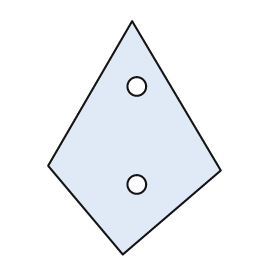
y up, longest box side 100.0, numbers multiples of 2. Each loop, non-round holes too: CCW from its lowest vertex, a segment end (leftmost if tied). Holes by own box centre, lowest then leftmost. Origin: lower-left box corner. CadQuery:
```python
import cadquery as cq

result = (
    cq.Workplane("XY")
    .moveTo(32.0, 0.0)
    .lineTo(74.0, 36.0)
    .lineTo(36.0, 100.0)
    .lineTo(0.0, 38.0)
    .close()
    .moveTo(38.0, 30.0)
    .circle(4.0)
    .moveTo(38.0, 72.0)
    .circle(4.0)
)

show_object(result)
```